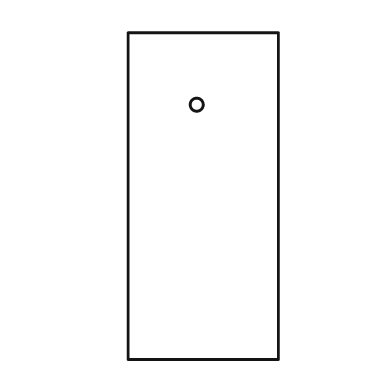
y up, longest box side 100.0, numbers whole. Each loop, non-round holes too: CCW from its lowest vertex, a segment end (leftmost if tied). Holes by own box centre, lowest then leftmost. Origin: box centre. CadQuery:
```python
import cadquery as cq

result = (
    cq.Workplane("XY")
    .moveTo(-23.0, -50.0)
    .lineTo(23.0, -50.0)
    .lineTo(23.0, 50.0)
    .lineTo(-23.0, 50.0)
    .close()
    .moveTo(-2.0, 28.0)
    .circle(2.0)
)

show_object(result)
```